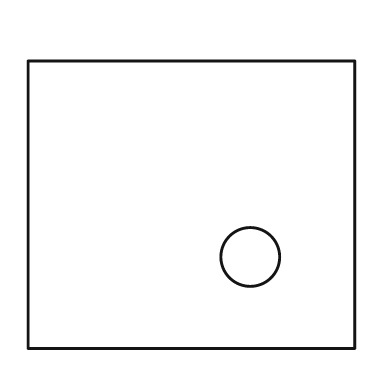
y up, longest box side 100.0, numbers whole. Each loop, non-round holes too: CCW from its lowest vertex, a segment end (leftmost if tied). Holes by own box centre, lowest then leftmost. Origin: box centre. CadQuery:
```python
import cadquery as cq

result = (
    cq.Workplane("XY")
    .moveTo(-50.0, -44.0)
    .lineTo(50.0, -44.0)
    .lineTo(50.0, 44.0)
    .lineTo(-50.0, 44.0)
    .close()
    .moveTo(18.0, -16.0)
    .circle(9.0)
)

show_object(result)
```